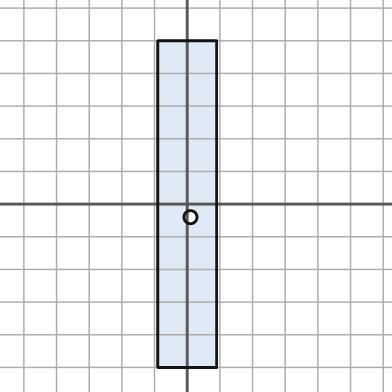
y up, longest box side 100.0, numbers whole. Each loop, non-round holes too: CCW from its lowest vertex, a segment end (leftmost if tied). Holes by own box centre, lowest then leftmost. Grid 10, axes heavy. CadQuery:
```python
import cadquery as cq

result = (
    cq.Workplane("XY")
    .moveTo(-9.0, -50.0)
    .lineTo(9.0, -50.0)
    .lineTo(9.0, 50.0)
    .lineTo(-9.0, 50.0)
    .close()
    .moveTo(1.0, -4.0)
    .circle(2.0)
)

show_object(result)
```